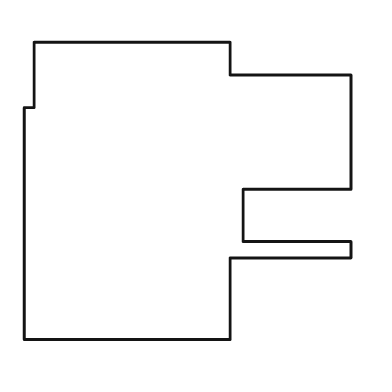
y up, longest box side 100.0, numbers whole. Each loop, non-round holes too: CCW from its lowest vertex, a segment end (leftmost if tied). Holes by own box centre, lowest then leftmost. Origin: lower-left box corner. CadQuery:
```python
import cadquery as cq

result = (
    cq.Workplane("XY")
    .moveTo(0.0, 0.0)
    .lineTo(63.0, 0.0)
    .lineTo(63.0, 25.0)
    .lineTo(100.0, 25.0)
    .lineTo(100.0, 30.0)
    .lineTo(67.0, 30.0)
    .lineTo(67.0, 46.0)
    .lineTo(100.0, 46.0)
    .lineTo(100.0, 81.0)
    .lineTo(63.0, 81.0)
    .lineTo(63.0, 91.0)
    .lineTo(3.0, 91.0)
    .lineTo(3.0, 71.0)
    .lineTo(0.0, 71.0)
    .close()
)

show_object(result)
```